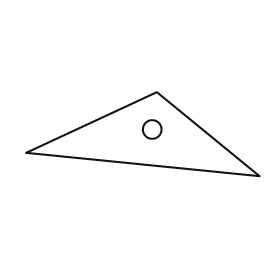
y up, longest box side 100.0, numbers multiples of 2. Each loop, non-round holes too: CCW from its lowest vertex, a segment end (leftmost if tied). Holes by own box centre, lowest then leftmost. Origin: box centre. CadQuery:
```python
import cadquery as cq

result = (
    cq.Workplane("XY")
    .moveTo(50.0, -18.0)
    .lineTo(6.0, 18.0)
    .lineTo(-50.0, -8.0)
    .close()
    .moveTo(4.0, 2.0)
    .circle(4.0)
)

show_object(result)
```